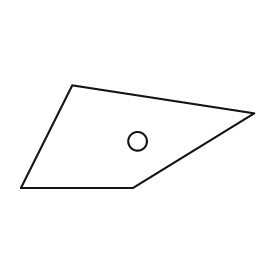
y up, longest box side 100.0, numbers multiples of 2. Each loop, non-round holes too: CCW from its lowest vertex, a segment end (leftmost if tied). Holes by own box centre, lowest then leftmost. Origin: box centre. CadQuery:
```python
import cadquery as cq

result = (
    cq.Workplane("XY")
    .moveTo(-50.0, -22.0)
    .lineTo(-2.0, -22.0)
    .lineTo(50.0, 10.0)
    .lineTo(-28.0, 22.0)
    .close()
    .moveTo(0.0, -2.0)
    .circle(4.0)
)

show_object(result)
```